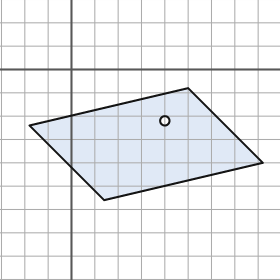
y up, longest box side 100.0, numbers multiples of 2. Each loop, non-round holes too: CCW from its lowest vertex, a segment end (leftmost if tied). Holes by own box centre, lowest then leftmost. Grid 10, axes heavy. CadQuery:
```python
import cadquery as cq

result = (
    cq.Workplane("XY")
    .moveTo(14.0, -56.0)
    .lineTo(82.0, -40.0)
    .lineTo(50.0, -8.0)
    .lineTo(-18.0, -24.0)
    .close()
    .moveTo(40.0, -22.0)
    .circle(2.0)
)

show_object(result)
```